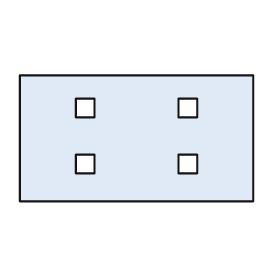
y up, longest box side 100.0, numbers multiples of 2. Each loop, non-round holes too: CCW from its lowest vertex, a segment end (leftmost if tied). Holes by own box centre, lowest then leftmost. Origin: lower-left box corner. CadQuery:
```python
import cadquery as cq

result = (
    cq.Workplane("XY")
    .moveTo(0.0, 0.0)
    .lineTo(100.0, 0.0)
    .lineTo(100.0, 54.0)
    .lineTo(0.0, 54.0)
    .close()
    .moveTo(24.0, 12.0)
    .lineTo(32.0, 12.0)
    .lineTo(32.0, 20.0)
    .lineTo(24.0, 20.0)
    .close()
    .moveTo(68.0, 12.0)
    .lineTo(76.0, 12.0)
    .lineTo(76.0, 20.0)
    .lineTo(68.0, 20.0)
    .close()
    .moveTo(24.0, 36.0)
    .lineTo(32.0, 36.0)
    .lineTo(32.0, 44.0)
    .lineTo(24.0, 44.0)
    .close()
    .moveTo(68.0, 36.0)
    .lineTo(76.0, 36.0)
    .lineTo(76.0, 44.0)
    .lineTo(68.0, 44.0)
    .close()
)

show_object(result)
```